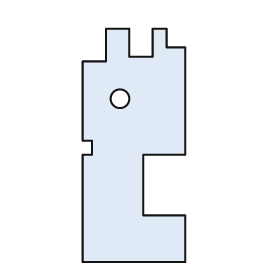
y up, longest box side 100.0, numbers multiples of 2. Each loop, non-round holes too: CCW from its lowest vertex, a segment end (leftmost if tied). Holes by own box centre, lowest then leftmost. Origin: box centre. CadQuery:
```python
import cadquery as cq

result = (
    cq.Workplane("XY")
    .moveTo(-22.0, -50.0)
    .lineTo(22.0, -50.0)
    .lineTo(22.0, -30.0)
    .lineTo(4.0, -30.0)
    .lineTo(4.0, -4.0)
    .lineTo(22.0, -4.0)
    .lineTo(22.0, 42.0)
    .lineTo(14.0, 42.0)
    .lineTo(14.0, 50.0)
    .lineTo(8.0, 50.0)
    .lineTo(8.0, 38.0)
    .lineTo(-2.0, 38.0)
    .lineTo(-2.0, 50.0)
    .lineTo(-12.0, 50.0)
    .lineTo(-12.0, 36.0)
    .lineTo(-22.0, 36.0)
    .lineTo(-22.0, 2.0)
    .lineTo(-18.0, 2.0)
    .lineTo(-18.0, -4.0)
    .lineTo(-22.0, -4.0)
    .close()
    .moveTo(-6.0, 20.0)
    .circle(4.0)
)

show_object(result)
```